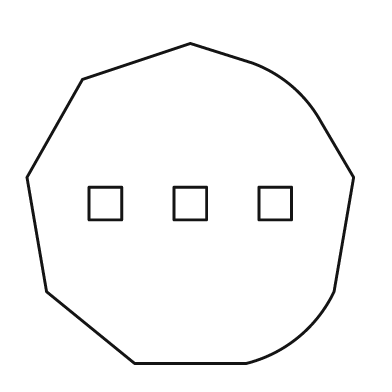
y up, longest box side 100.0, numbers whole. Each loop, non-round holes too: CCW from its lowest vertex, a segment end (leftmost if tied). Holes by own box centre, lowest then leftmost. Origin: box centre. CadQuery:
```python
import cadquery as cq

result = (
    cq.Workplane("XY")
    .moveTo(-17.0, -49.0)
    .lineTo(17.0, -49.0)
    .threePointArc((33.0, -41.0), (44.0, -27.0))
    .lineTo(50.0, 8.0)
    .lineTo(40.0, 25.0)
    .threePointArc((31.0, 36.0), (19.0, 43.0))
    .lineTo(0.0, 49.0)
    .lineTo(-33.0, 38.0)
    .lineTo(-50.0, 8.0)
    .lineTo(-44.0, -27.0)
    .close()
    .moveTo(-31.0, -5.0)
    .lineTo(-21.0, -5.0)
    .lineTo(-21.0, 5.0)
    .lineTo(-31.0, 5.0)
    .close()
    .moveTo(-5.0, -5.0)
    .lineTo(5.0, -5.0)
    .lineTo(5.0, 5.0)
    .lineTo(-5.0, 5.0)
    .close()
    .moveTo(21.0, -5.0)
    .lineTo(31.0, -5.0)
    .lineTo(31.0, 5.0)
    .lineTo(21.0, 5.0)
    .close()
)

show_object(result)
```